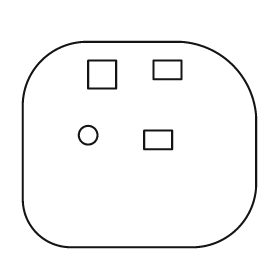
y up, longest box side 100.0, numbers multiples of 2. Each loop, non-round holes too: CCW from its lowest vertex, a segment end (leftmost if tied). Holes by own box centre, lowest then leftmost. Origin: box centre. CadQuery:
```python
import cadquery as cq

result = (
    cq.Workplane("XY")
    .moveTo(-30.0, -44.0)
    .lineTo(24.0, -44.0)
    .threePointArc((42.0, -36.0), (50.0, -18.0))
    .lineTo(50.0, 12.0)
    .threePointArc((40.0, 34.0), (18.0, 44.0))
    .lineTo(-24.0, 44.0)
    .threePointArc((-42.0, 36.0), (-50.0, 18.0))
    .lineTo(-50.0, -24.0)
    .threePointArc((-44.0, -38.0), (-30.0, -44.0))
    .close()
    .moveTo(2.0, -2.0)
    .lineTo(14.0, -2.0)
    .lineTo(14.0, 6.0)
    .lineTo(2.0, 6.0)
    .close()
    .moveTo(-22.0, 4.0)
    .circle(4.0)
    .moveTo(-22.0, 24.0)
    .lineTo(-10.0, 24.0)
    .lineTo(-10.0, 36.0)
    .lineTo(-22.0, 36.0)
    .close()
    .moveTo(6.0, 28.0)
    .lineTo(18.0, 28.0)
    .lineTo(18.0, 36.0)
    .lineTo(6.0, 36.0)
    .close()
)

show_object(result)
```